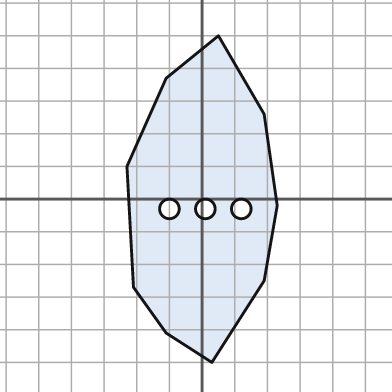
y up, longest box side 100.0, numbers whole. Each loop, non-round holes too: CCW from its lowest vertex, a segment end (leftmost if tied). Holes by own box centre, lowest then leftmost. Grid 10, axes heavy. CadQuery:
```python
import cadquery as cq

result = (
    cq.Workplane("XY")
    .moveTo(3.0, -50.0)
    .lineTo(19.0, -25.0)
    .lineTo(23.0, -2.0)
    .lineTo(19.0, 26.0)
    .lineTo(5.0, 50.0)
    .lineTo(-11.0, 37.0)
    .lineTo(-23.0, 10.0)
    .lineTo(-21.0, -27.0)
    .lineTo(-11.0, -41.0)
    .close()
    .moveTo(-10.0, -3.0)
    .circle(3.0)
    .moveTo(1.0, -3.0)
    .circle(3.0)
    .moveTo(12.0, -3.0)
    .circle(3.0)
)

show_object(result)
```